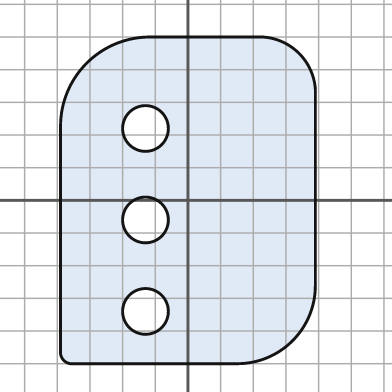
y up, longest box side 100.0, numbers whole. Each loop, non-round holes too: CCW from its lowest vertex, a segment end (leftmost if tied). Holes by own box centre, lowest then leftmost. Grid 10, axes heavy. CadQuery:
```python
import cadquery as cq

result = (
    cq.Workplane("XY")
    .moveTo(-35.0, -50.0)
    .lineTo(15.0, -50.0)
    .threePointArc((32.0, -43.0), (39.0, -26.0))
    .lineTo(39.0, 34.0)
    .threePointArc((34.0, 45.0), (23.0, 50.0))
    .lineTo(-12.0, 50.0)
    .threePointArc((-31.0, 42.0), (-39.0, 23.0))
    .lineTo(-39.0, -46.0)
    .threePointArc((-38.0, -49.0), (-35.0, -50.0))
    .close()
    .moveTo(-13.0, -34.0)
    .circle(7.0)
    .moveTo(-13.0, -6.0)
    .circle(7.0)
    .moveTo(-13.0, 22.0)
    .circle(7.0)
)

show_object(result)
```